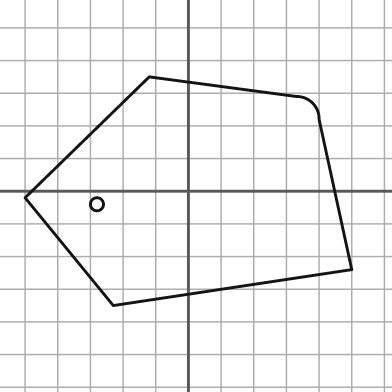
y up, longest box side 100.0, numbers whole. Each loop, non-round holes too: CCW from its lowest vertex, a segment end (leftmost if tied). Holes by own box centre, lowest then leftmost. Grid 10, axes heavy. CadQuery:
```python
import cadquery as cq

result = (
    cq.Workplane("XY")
    .moveTo(-23.0, -35.0)
    .lineTo(50.0, -24.0)
    .lineTo(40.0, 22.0)
    .threePointArc((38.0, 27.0), (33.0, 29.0))
    .lineTo(-12.0, 35.0)
    .lineTo(-50.0, -2.0)
    .close()
    .moveTo(-28.0, -4.0)
    .circle(2.0)
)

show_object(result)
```